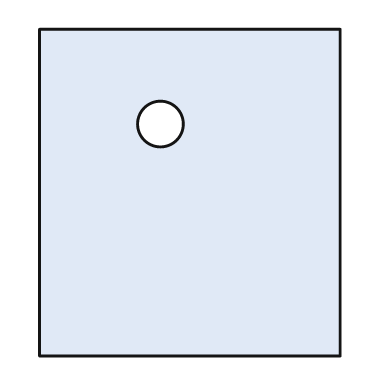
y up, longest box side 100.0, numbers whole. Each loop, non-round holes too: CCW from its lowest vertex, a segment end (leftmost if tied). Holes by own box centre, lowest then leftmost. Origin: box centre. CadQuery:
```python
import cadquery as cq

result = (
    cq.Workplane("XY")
    .moveTo(-46.0, -50.0)
    .lineTo(46.0, -50.0)
    .lineTo(46.0, 50.0)
    .lineTo(-46.0, 50.0)
    .close()
    .moveTo(-9.0, 21.0)
    .circle(7.0)
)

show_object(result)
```